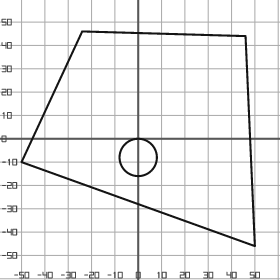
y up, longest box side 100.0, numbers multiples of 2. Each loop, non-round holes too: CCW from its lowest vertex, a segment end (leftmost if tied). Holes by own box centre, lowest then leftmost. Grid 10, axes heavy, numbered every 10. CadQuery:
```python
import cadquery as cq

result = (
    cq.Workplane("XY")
    .moveTo(50.0, -46.0)
    .lineTo(46.0, 44.0)
    .lineTo(-24.0, 46.0)
    .lineTo(-50.0, -10.0)
    .close()
    .moveTo(0.0, -8.0)
    .circle(8.0)
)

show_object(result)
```